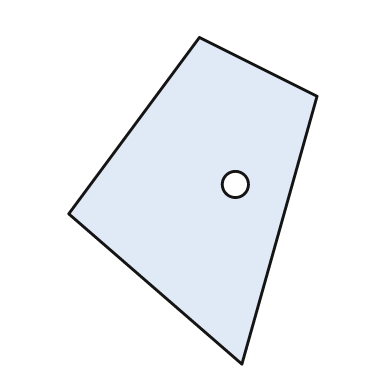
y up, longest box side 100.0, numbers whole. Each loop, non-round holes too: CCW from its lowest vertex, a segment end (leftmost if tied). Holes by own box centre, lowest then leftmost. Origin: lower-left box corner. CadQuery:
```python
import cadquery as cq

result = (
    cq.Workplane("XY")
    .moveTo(53.0, 0.0)
    .lineTo(76.0, 82.0)
    .lineTo(40.0, 100.0)
    .lineTo(0.0, 46.0)
    .close()
    .moveTo(51.0, 55.0)
    .circle(4.0)
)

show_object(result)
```